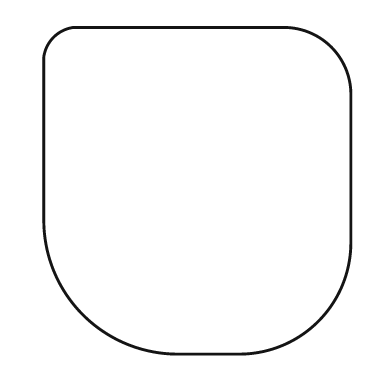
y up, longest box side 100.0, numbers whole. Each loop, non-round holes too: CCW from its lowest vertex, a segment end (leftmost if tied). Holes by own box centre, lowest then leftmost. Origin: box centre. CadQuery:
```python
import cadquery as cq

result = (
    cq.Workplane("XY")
    .moveTo(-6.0, -50.0)
    .lineTo(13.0, -50.0)
    .threePointArc((37.0, -40.0), (47.0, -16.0))
    .lineTo(47.0, 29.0)
    .threePointArc((41.0, 44.0), (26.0, 50.0))
    .lineTo(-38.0, 50.0)
    .threePointArc((-44.0, 47.0), (-47.0, 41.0))
    .lineTo(-47.0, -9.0)
    .threePointArc((-35.0, -38.0), (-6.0, -50.0))
    .close()
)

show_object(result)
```